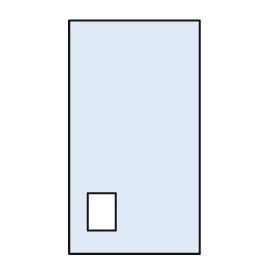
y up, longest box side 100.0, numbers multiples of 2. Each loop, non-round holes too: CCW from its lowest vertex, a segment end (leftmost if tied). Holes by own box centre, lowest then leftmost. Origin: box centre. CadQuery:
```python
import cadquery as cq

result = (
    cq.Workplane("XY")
    .moveTo(-28.0, -50.0)
    .lineTo(28.0, -50.0)
    .lineTo(28.0, 50.0)
    .lineTo(-28.0, 50.0)
    .close()
    .moveTo(-20.0, -40.0)
    .lineTo(-8.0, -40.0)
    .lineTo(-8.0, -24.0)
    .lineTo(-20.0, -24.0)
    .close()
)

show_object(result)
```